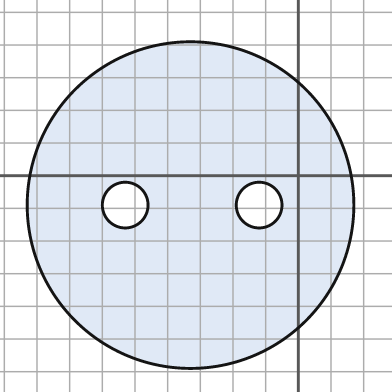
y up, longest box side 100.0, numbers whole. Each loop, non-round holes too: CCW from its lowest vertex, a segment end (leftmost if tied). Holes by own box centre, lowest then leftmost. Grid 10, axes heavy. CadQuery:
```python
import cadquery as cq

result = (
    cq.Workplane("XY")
    .moveTo(-33.0, -9.0)
    .circle(50.0)
    .moveTo(-53.0, -9.0)
    .circle(7.0)
    .moveTo(-12.0, -9.0)
    .circle(7.0)
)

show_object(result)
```